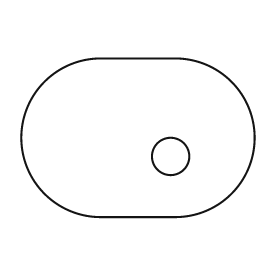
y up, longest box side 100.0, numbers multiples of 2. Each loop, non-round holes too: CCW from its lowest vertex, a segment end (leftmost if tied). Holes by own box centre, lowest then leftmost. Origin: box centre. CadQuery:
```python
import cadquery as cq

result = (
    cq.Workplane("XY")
    .moveTo(-16.0, -34.0)
    .lineTo(16.0, -34.0)
    .threePointArc((50.0, 0.0), (16.0, 34.0))
    .lineTo(-16.0, 34.0)
    .threePointArc((-50.0, 0.0), (-16.0, -34.0))
    .close()
    .moveTo(14.0, -8.0)
    .circle(8.0)
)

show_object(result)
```